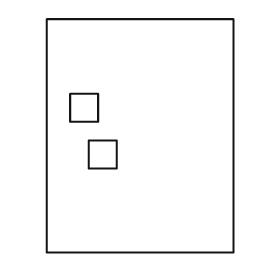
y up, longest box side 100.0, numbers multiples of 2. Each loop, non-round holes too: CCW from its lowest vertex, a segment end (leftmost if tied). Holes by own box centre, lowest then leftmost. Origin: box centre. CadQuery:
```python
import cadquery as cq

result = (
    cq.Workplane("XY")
    .moveTo(-40.0, -50.0)
    .lineTo(40.0, -50.0)
    .lineTo(40.0, 50.0)
    .lineTo(-40.0, 50.0)
    .close()
    .moveTo(-22.0, -14.0)
    .lineTo(-10.0, -14.0)
    .lineTo(-10.0, -2.0)
    .lineTo(-22.0, -2.0)
    .close()
    .moveTo(-30.0, 6.0)
    .lineTo(-18.0, 6.0)
    .lineTo(-18.0, 18.0)
    .lineTo(-30.0, 18.0)
    .close()
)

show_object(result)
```